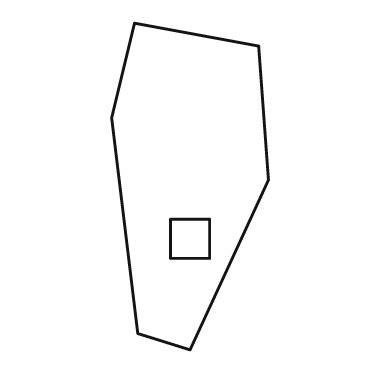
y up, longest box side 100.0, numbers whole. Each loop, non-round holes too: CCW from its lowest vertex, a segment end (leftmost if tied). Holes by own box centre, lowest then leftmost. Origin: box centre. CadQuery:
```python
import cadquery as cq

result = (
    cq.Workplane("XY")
    .moveTo(0.0, -50.0)
    .lineTo(24.0, 2.0)
    .lineTo(21.0, 43.0)
    .lineTo(-17.0, 50.0)
    .lineTo(-24.0, 21.0)
    .lineTo(-16.0, -45.0)
    .close()
    .moveTo(-6.0, -22.0)
    .lineTo(6.0, -22.0)
    .lineTo(6.0, -10.0)
    .lineTo(-6.0, -10.0)
    .close()
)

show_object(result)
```